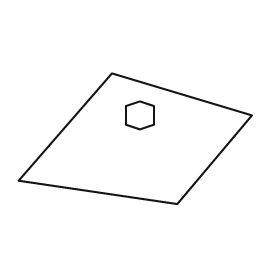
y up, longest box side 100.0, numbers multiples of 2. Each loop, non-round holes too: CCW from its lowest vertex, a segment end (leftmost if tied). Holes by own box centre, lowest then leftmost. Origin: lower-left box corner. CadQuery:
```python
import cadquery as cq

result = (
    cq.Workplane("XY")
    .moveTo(68.0, 0.0)
    .lineTo(100.0, 38.0)
    .lineTo(40.0, 56.0)
    .lineTo(0.0, 10.0)
    .close()
    .moveTo(52.0, 32.0)
    .lineTo(58.0, 34.0)
    .lineTo(58.0, 42.0)
    .lineTo(52.0, 44.0)
    .lineTo(46.0, 42.0)
    .lineTo(46.0, 34.0)
    .close()
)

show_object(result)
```